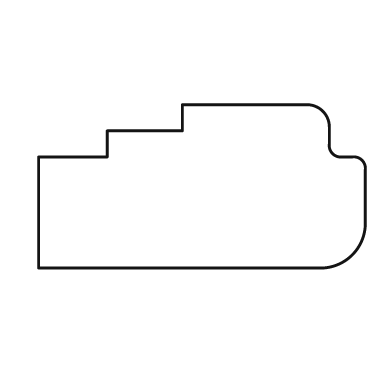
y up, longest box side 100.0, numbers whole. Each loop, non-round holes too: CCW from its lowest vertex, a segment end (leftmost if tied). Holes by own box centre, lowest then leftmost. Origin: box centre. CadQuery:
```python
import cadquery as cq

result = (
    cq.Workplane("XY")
    .moveTo(-50.0, -25.0)
    .lineTo(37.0, -25.0)
    .threePointArc((46.0, -21.0), (50.0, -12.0))
    .lineTo(50.0, 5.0)
    .threePointArc((49.0, 8.0), (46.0, 9.0))
    .lineTo(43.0, 9.0)
    .threePointArc((40.0, 10.0), (39.0, 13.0))
    .lineTo(39.0, 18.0)
    .threePointArc((37.0, 23.0), (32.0, 25.0))
    .lineTo(-6.0, 25.0)
    .lineTo(-6.0, 17.0)
    .lineTo(-29.0, 17.0)
    .lineTo(-29.0, 9.0)
    .lineTo(-50.0, 9.0)
    .close()
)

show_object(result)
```